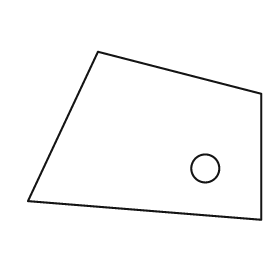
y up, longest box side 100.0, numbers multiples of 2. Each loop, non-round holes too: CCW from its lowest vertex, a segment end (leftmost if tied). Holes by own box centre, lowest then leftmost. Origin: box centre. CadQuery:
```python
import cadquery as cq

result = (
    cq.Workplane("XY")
    .moveTo(50.0, -36.0)
    .lineTo(50.0, 18.0)
    .lineTo(-20.0, 36.0)
    .lineTo(-50.0, -28.0)
    .close()
    .moveTo(26.0, -14.0)
    .circle(6.0)
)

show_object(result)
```